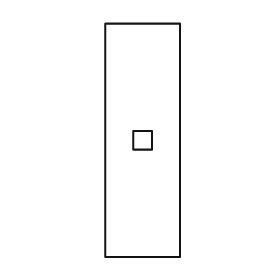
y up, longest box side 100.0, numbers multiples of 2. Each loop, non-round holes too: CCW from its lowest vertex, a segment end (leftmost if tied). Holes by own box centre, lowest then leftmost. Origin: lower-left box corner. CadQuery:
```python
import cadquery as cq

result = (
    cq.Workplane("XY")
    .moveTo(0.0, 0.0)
    .lineTo(32.0, 0.0)
    .lineTo(32.0, 100.0)
    .lineTo(0.0, 100.0)
    .close()
    .moveTo(12.0, 46.0)
    .lineTo(20.0, 46.0)
    .lineTo(20.0, 54.0)
    .lineTo(12.0, 54.0)
    .close()
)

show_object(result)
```